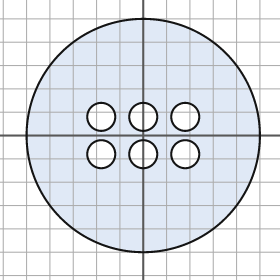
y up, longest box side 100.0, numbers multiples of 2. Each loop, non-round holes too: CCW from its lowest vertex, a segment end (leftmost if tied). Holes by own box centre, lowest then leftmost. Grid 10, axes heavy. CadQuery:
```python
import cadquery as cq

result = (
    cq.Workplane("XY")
    .moveTo(0.0, 0.0)
    .circle(50.0)
    .moveTo(-18.0, -8.0)
    .circle(6.0)
    .moveTo(0.0, -8.0)
    .circle(6.0)
    .moveTo(18.0, -8.0)
    .circle(6.0)
    .moveTo(-18.0, 8.0)
    .circle(6.0)
    .moveTo(0.0, 8.0)
    .circle(6.0)
    .moveTo(18.0, 8.0)
    .circle(6.0)
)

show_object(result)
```